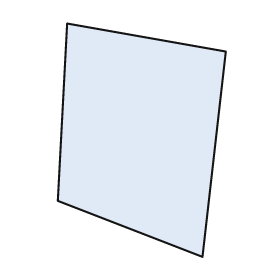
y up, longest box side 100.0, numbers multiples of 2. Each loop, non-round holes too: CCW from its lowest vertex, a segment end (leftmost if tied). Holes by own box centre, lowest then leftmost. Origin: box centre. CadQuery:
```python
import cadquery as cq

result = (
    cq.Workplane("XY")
    .moveTo(26.0, -50.0)
    .lineTo(36.0, 38.0)
    .lineTo(-32.0, 50.0)
    .lineTo(-36.0, -26.0)
    .close()
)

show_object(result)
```